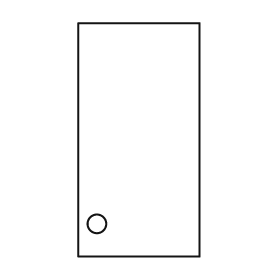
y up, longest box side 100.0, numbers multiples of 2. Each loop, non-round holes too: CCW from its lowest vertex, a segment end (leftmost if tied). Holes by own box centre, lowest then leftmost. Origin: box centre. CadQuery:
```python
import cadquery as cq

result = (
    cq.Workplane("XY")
    .moveTo(-26.0, -50.0)
    .lineTo(26.0, -50.0)
    .lineTo(26.0, 50.0)
    .lineTo(-26.0, 50.0)
    .close()
    .moveTo(-18.0, -36.0)
    .circle(4.0)
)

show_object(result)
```